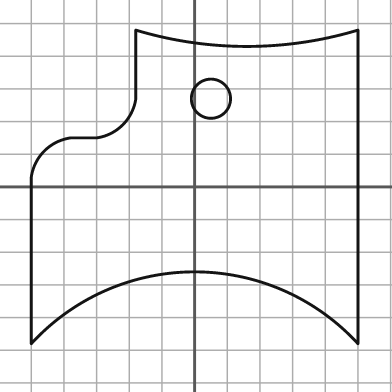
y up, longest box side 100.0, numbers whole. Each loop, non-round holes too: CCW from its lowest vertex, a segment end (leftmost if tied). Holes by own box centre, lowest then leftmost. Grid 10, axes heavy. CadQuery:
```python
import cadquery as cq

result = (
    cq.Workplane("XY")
    .moveTo(-50.0, -48.0)
    .threePointArc((0.0, -26.0), (50.0, -48.0))
    .lineTo(50.0, 48.0)
    .threePointArc((16.0, 43.0), (-18.0, 48.0))
    .lineTo(-18.0, 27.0)
    .threePointArc((-22.0, 19.0), (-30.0, 15.0))
    .lineTo(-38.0, 15.0)
    .threePointArc((-46.0, 11.0), (-50.0, 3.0))
    .close()
    .moveTo(5.0, 27.0)
    .circle(6.0)
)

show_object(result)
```